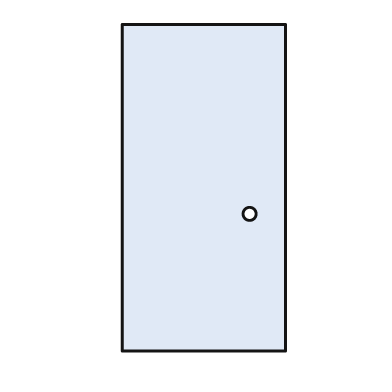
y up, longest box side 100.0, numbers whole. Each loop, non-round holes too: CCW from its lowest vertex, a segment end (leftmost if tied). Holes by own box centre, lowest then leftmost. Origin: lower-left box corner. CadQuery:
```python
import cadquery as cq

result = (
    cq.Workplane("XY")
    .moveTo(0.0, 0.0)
    .lineTo(50.0, 0.0)
    .lineTo(50.0, 100.0)
    .lineTo(0.0, 100.0)
    .close()
    .moveTo(39.0, 42.0)
    .circle(2.0)
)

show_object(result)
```